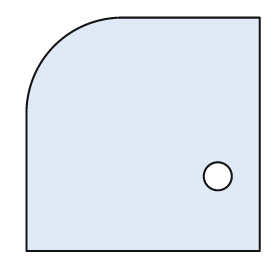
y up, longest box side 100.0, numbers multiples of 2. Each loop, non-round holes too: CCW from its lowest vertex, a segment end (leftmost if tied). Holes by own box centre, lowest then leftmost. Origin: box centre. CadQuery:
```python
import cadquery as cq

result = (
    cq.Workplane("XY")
    .moveTo(-50.0, -50.0)
    .lineTo(50.0, -50.0)
    .lineTo(50.0, 50.0)
    .lineTo(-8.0, 50.0)
    .threePointArc((-38.0, 38.0), (-50.0, 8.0))
    .close()
    .moveTo(32.0, -18.0)
    .circle(6.0)
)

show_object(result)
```